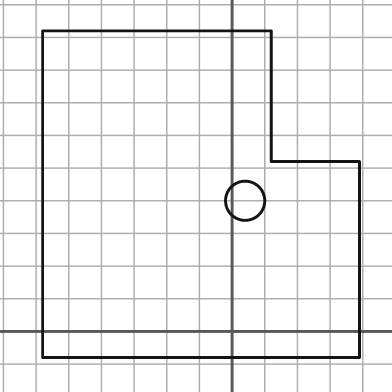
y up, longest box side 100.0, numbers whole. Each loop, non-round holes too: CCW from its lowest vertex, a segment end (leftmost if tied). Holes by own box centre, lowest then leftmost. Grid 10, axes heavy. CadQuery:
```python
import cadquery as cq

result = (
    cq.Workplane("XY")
    .moveTo(-58.0, -8.0)
    .lineTo(39.0, -8.0)
    .lineTo(39.0, 52.0)
    .lineTo(12.0, 52.0)
    .lineTo(12.0, 92.0)
    .lineTo(-58.0, 92.0)
    .close()
    .moveTo(4.0, 40.0)
    .circle(6.0)
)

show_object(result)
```